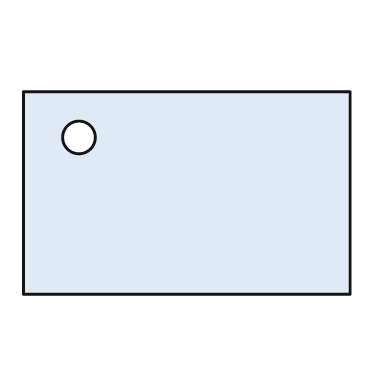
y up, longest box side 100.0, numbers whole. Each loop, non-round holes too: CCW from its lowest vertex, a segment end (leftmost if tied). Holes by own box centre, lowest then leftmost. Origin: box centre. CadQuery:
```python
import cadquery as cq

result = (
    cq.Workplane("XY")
    .moveTo(-50.0, -31.0)
    .lineTo(50.0, -31.0)
    .lineTo(50.0, 31.0)
    .lineTo(-50.0, 31.0)
    .close()
    .moveTo(-33.0, 17.0)
    .circle(5.0)
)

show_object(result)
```